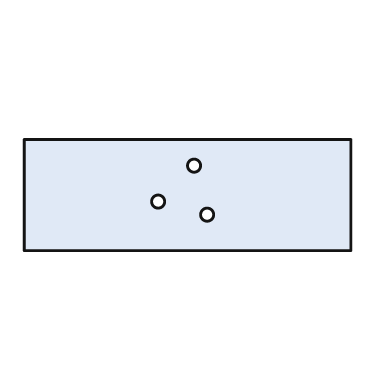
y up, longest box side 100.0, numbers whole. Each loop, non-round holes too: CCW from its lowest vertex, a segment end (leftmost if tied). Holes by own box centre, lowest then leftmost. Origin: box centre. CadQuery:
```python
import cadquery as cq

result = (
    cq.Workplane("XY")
    .moveTo(-50.0, -17.0)
    .lineTo(50.0, -17.0)
    .lineTo(50.0, 17.0)
    .lineTo(-50.0, 17.0)
    .close()
    .moveTo(6.0, -6.0)
    .circle(2.0)
    .moveTo(-9.0, -2.0)
    .circle(2.0)
    .moveTo(2.0, 9.0)
    .circle(2.0)
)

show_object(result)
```